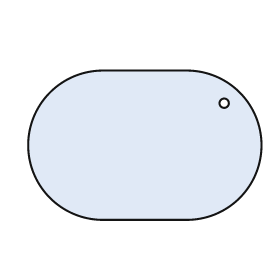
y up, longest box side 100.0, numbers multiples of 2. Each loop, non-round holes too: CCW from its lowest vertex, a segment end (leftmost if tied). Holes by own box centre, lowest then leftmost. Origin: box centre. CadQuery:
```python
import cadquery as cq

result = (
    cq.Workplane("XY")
    .moveTo(-18.0, -32.0)
    .lineTo(18.0, -32.0)
    .threePointArc((50.0, 0.0), (18.0, 32.0))
    .lineTo(-18.0, 32.0)
    .threePointArc((-50.0, 0.0), (-18.0, -32.0))
    .close()
    .moveTo(34.0, 18.0)
    .circle(2.0)
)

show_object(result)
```